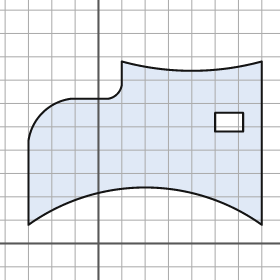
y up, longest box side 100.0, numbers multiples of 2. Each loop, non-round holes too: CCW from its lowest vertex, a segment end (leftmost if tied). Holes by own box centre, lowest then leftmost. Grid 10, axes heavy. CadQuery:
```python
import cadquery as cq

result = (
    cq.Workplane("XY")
    .moveTo(-30.0, 8.0)
    .threePointArc((20.0, 24.0), (70.0, 8.0))
    .lineTo(70.0, 78.0)
    .threePointArc((40.0, 74.0), (10.0, 78.0))
    .lineTo(10.0, 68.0)
    .threePointArc((8.0, 64.0), (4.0, 62.0))
    .lineTo(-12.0, 62.0)
    .threePointArc((-24.0, 56.0), (-30.0, 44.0))
    .close()
    .moveTo(50.0, 48.0)
    .lineTo(62.0, 48.0)
    .lineTo(62.0, 56.0)
    .lineTo(50.0, 56.0)
    .close()
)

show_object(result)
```